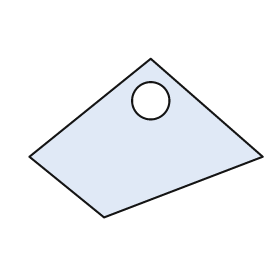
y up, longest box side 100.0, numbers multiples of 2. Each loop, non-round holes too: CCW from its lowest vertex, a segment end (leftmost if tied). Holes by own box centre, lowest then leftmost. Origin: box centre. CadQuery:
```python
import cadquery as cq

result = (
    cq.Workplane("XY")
    .moveTo(-18.0, -34.0)
    .lineTo(50.0, -8.0)
    .lineTo(2.0, 34.0)
    .lineTo(-50.0, -8.0)
    .close()
    .moveTo(2.0, 16.0)
    .circle(8.0)
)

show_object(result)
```